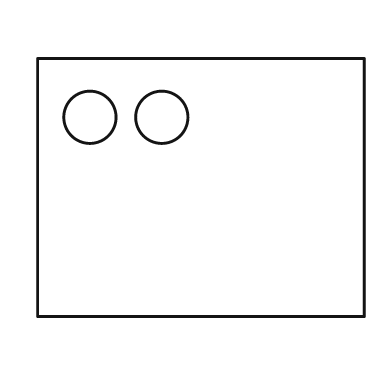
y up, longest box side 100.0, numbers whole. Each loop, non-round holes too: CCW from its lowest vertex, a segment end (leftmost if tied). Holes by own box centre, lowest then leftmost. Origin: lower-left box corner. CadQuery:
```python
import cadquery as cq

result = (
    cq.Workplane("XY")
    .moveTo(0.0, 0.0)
    .lineTo(100.0, 0.0)
    .lineTo(100.0, 79.0)
    .lineTo(0.0, 79.0)
    .close()
    .moveTo(16.0, 61.0)
    .circle(8.0)
    .moveTo(38.0, 61.0)
    .circle(8.0)
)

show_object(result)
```